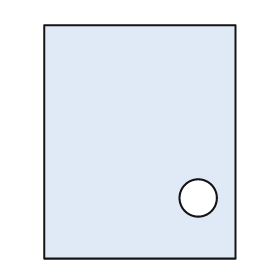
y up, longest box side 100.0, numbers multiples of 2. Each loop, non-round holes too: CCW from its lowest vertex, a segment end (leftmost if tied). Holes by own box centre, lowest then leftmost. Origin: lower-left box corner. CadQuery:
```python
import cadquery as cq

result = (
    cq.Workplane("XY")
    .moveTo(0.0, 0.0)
    .lineTo(82.0, 0.0)
    .lineTo(82.0, 100.0)
    .lineTo(0.0, 100.0)
    .close()
    .moveTo(66.0, 26.0)
    .circle(8.0)
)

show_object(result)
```